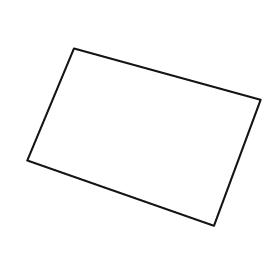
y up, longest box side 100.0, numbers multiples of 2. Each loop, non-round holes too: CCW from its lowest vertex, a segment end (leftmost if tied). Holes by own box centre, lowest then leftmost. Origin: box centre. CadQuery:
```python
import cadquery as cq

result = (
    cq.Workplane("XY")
    .moveTo(30.0, -38.0)
    .lineTo(50.0, 16.0)
    .lineTo(-30.0, 38.0)
    .lineTo(-50.0, -10.0)
    .close()
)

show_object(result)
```